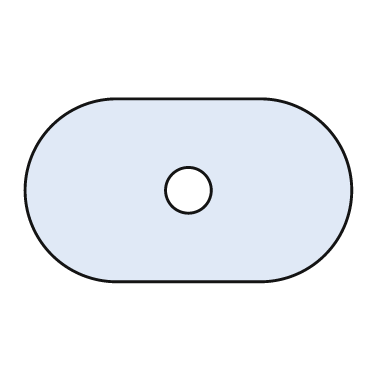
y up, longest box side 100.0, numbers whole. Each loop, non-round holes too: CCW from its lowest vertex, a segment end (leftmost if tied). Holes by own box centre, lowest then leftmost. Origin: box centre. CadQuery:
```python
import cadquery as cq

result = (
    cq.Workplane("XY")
    .moveTo(-22.0, -28.0)
    .lineTo(22.0, -28.0)
    .threePointArc((50.0, 0.0), (22.0, 28.0))
    .lineTo(-22.0, 28.0)
    .threePointArc((-50.0, 0.0), (-22.0, -28.0))
    .close()
    .moveTo(0.0, 0.0)
    .circle(7.0)
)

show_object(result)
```